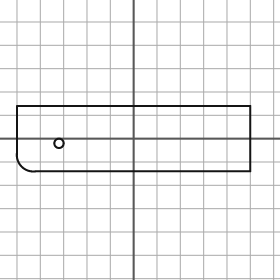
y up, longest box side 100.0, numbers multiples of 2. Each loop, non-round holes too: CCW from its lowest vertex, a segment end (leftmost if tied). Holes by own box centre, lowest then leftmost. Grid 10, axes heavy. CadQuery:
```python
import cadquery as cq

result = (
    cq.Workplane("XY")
    .moveTo(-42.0, -14.0)
    .lineTo(50.0, -14.0)
    .lineTo(50.0, 14.0)
    .lineTo(-50.0, 14.0)
    .lineTo(-50.0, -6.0)
    .threePointArc((-48.0, -12.0), (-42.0, -14.0))
    .close()
    .moveTo(-32.0, -2.0)
    .circle(2.0)
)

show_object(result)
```